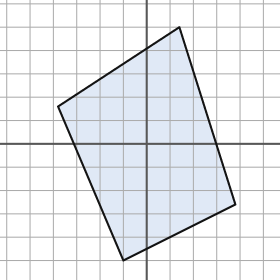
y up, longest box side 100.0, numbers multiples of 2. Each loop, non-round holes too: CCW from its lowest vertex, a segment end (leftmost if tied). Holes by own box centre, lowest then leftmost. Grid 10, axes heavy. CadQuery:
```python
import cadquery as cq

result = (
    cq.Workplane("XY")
    .moveTo(-10.0, -50.0)
    .lineTo(38.0, -26.0)
    .lineTo(14.0, 50.0)
    .lineTo(-38.0, 16.0)
    .close()
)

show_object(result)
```